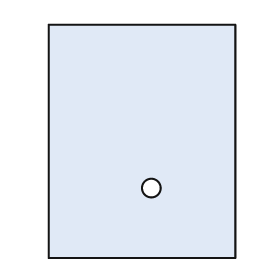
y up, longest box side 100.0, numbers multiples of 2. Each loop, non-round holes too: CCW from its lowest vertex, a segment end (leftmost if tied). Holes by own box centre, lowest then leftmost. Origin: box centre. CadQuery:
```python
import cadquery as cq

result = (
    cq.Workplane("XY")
    .moveTo(-40.0, -50.0)
    .lineTo(40.0, -50.0)
    .lineTo(40.0, 50.0)
    .lineTo(-40.0, 50.0)
    .close()
    .moveTo(4.0, -20.0)
    .circle(4.0)
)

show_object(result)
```